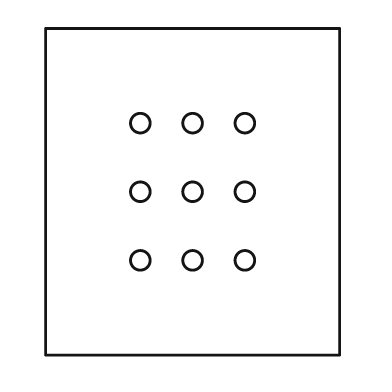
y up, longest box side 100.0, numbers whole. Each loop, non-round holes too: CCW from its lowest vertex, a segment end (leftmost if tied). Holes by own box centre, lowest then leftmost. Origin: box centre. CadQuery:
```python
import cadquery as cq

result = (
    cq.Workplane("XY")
    .moveTo(-45.0, -50.0)
    .lineTo(45.0, -50.0)
    .lineTo(45.0, 50.0)
    .lineTo(-45.0, 50.0)
    .close()
    .moveTo(-16.0, -21.0)
    .circle(3.0)
    .moveTo(0.0, -21.0)
    .circle(3.0)
    .moveTo(16.0, -21.0)
    .circle(3.0)
    .moveTo(-16.0, 0.0)
    .circle(3.0)
    .moveTo(0.0, 0.0)
    .circle(3.0)
    .moveTo(16.0, 0.0)
    .circle(3.0)
    .moveTo(-16.0, 21.0)
    .circle(3.0)
    .moveTo(0.0, 21.0)
    .circle(3.0)
    .moveTo(16.0, 21.0)
    .circle(3.0)
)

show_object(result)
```